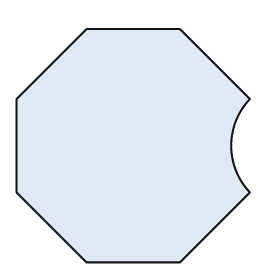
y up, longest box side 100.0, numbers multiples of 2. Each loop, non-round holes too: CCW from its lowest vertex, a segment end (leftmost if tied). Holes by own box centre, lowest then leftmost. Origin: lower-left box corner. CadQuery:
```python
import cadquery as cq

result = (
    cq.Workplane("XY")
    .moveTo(30.0, 0.0)
    .lineTo(70.0, 0.0)
    .lineTo(100.0, 30.0)
    .threePointArc((92.0, 50.0), (100.0, 70.0))
    .lineTo(70.0, 100.0)
    .lineTo(30.0, 100.0)
    .lineTo(0.0, 70.0)
    .lineTo(0.0, 30.0)
    .close()
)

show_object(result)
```